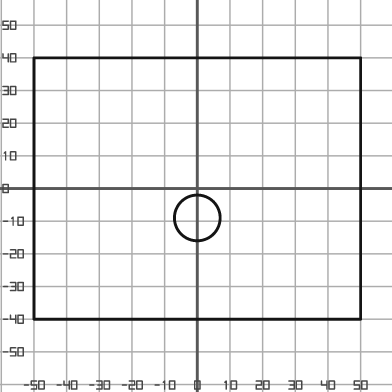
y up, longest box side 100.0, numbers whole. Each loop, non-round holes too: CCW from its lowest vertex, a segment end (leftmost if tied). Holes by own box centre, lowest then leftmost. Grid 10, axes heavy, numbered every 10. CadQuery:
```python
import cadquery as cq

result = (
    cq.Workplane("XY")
    .moveTo(-50.0, -40.0)
    .lineTo(50.0, -40.0)
    .lineTo(50.0, 40.0)
    .lineTo(-50.0, 40.0)
    .close()
    .moveTo(0.0, -9.0)
    .circle(7.0)
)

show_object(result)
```